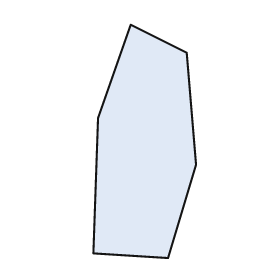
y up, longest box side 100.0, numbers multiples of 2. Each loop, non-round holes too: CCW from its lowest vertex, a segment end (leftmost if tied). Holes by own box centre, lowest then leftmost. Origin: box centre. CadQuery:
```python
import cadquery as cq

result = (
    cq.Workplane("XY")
    .moveTo(10.0, -50.0)
    .lineTo(22.0, -10.0)
    .lineTo(18.0, 38.0)
    .lineTo(-6.0, 50.0)
    .lineTo(-20.0, 10.0)
    .lineTo(-22.0, -48.0)
    .close()
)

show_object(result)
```